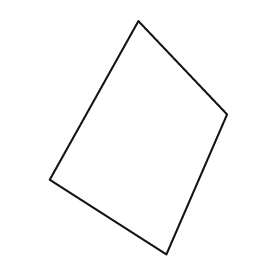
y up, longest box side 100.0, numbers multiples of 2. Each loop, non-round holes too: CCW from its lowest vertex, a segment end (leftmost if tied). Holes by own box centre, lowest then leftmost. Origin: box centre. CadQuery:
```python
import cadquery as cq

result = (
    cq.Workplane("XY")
    .moveTo(12.0, -50.0)
    .lineTo(38.0, 10.0)
    .lineTo(0.0, 50.0)
    .lineTo(-38.0, -18.0)
    .close()
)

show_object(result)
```